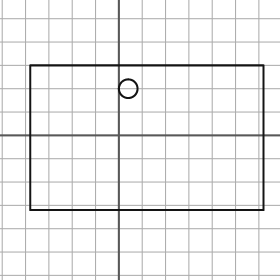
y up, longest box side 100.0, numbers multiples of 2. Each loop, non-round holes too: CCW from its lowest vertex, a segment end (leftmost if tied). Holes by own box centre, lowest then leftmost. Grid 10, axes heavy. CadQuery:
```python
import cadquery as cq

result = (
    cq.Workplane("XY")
    .moveTo(-38.0, -32.0)
    .lineTo(62.0, -32.0)
    .lineTo(62.0, 30.0)
    .lineTo(-38.0, 30.0)
    .close()
    .moveTo(4.0, 20.0)
    .circle(4.0)
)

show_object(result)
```